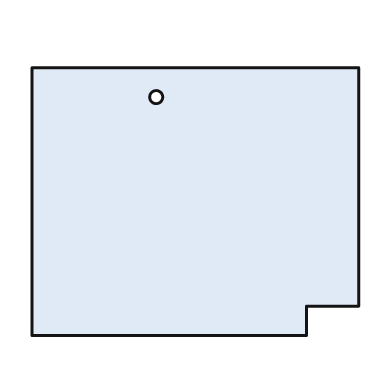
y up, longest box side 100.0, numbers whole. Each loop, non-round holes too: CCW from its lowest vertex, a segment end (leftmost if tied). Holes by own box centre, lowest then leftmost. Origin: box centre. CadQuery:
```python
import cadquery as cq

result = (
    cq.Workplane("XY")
    .moveTo(-50.0, -41.0)
    .lineTo(34.0, -41.0)
    .lineTo(34.0, -32.0)
    .lineTo(50.0, -32.0)
    .lineTo(50.0, 41.0)
    .lineTo(-50.0, 41.0)
    .close()
    .moveTo(-12.0, 32.0)
    .circle(2.0)
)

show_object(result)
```